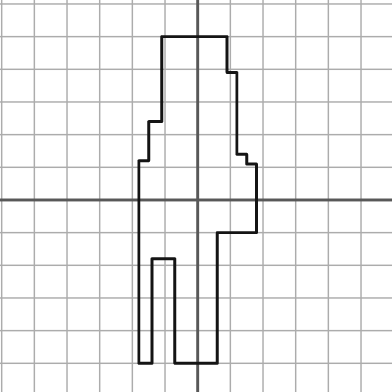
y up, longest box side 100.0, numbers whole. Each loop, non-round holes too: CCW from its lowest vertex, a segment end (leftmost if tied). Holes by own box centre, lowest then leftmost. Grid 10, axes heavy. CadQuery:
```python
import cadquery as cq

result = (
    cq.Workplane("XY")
    .moveTo(-18.0, -50.0)
    .lineTo(-14.0, -50.0)
    .lineTo(-14.0, -18.0)
    .lineTo(-7.0, -18.0)
    .lineTo(-7.0, -50.0)
    .lineTo(6.0, -50.0)
    .lineTo(6.0, -10.0)
    .lineTo(18.0, -10.0)
    .lineTo(18.0, 11.0)
    .lineTo(15.0, 11.0)
    .lineTo(15.0, 14.0)
    .lineTo(12.0, 14.0)
    .lineTo(12.0, 39.0)
    .lineTo(9.0, 39.0)
    .lineTo(9.0, 50.0)
    .lineTo(-11.0, 50.0)
    .lineTo(-11.0, 24.0)
    .lineTo(-15.0, 24.0)
    .lineTo(-15.0, 12.0)
    .lineTo(-18.0, 12.0)
    .close()
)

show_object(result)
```